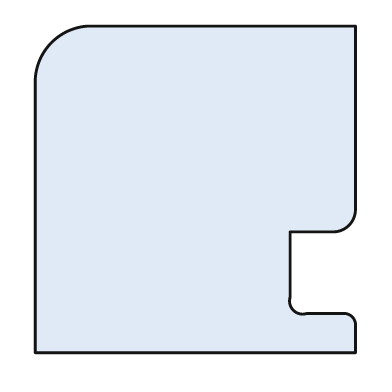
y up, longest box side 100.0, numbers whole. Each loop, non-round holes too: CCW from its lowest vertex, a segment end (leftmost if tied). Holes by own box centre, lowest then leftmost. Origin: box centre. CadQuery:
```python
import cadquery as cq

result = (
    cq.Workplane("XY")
    .moveTo(-49.0, -50.0)
    .lineTo(49.0, -50.0)
    .lineTo(49.0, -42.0)
    .threePointArc((48.0, -39.0), (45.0, -38.0))
    .lineTo(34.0, -38.0)
    .threePointArc((30.0, -37.0), (29.0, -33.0))
    .lineTo(29.0, -13.0)
    .lineTo(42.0, -13.0)
    .threePointArc((47.0, -11.0), (49.0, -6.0))
    .lineTo(49.0, 50.0)
    .lineTo(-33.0, 50.0)
    .threePointArc((-44.0, 45.0), (-49.0, 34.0))
    .close()
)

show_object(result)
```